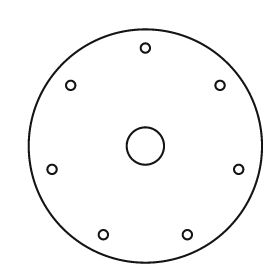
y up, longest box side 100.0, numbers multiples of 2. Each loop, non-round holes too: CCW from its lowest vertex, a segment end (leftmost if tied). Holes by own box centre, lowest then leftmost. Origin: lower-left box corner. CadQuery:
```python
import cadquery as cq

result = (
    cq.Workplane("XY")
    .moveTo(50.0, 50.0)
    .circle(50.0)
    .moveTo(32.0, 12.0)
    .circle(2.0)
    .moveTo(68.0, 12.0)
    .circle(2.0)
    .moveTo(10.0, 40.0)
    .circle(2.0)
    .moveTo(90.0, 40.0)
    .circle(2.0)
    .moveTo(50.0, 50.0)
    .circle(8.0)
    .moveTo(18.0, 76.0)
    .circle(2.0)
    .moveTo(82.0, 76.0)
    .circle(2.0)
    .moveTo(50.0, 92.0)
    .circle(2.0)
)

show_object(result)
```